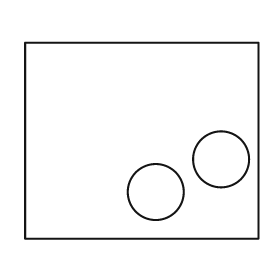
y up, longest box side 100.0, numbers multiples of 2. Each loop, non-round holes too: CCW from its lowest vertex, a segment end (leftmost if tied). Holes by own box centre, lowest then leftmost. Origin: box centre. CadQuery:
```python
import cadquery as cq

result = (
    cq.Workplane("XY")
    .moveTo(-50.0, -42.0)
    .lineTo(50.0, -42.0)
    .lineTo(50.0, 42.0)
    .lineTo(-50.0, 42.0)
    .close()
    .moveTo(6.0, -22.0)
    .circle(12.0)
    .moveTo(34.0, -8.0)
    .circle(12.0)
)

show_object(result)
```